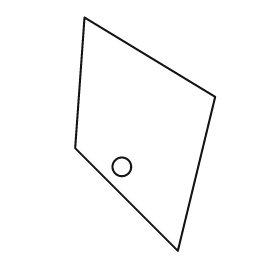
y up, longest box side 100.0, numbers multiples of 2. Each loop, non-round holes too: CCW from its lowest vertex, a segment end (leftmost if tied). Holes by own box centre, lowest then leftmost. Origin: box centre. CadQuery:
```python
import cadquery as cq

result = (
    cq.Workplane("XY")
    .moveTo(14.0, -50.0)
    .lineTo(30.0, 16.0)
    .lineTo(-26.0, 50.0)
    .lineTo(-30.0, -6.0)
    .close()
    .moveTo(-10.0, -14.0)
    .circle(4.0)
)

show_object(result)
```